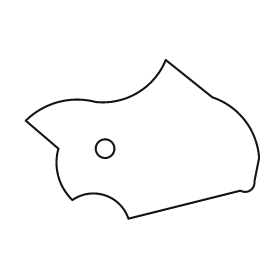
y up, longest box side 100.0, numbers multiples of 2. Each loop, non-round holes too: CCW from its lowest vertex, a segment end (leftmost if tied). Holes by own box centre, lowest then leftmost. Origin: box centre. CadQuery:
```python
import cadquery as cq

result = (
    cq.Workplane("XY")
    .moveTo(-6.0, -34.0)
    .lineTo(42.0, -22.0)
    .threePointArc((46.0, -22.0), (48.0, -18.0))
    .lineTo(50.0, -8.0)
    .threePointArc((44.0, 8.0), (30.0, 18.0))
    .lineTo(10.0, 34.0)
    .threePointArc((-2.0, 20.0), (-20.0, 16.0))
    .threePointArc((-36.0, 16.0), (-50.0, 8.0))
    .lineTo(-36.0, -4.0)
    .threePointArc((-36.0, -16.0), (-30.0, -26.0))
    .threePointArc((-16.0, -24.0), (-6.0, -34.0))
    .close()
    .moveTo(-16.0, -4.0)
    .circle(4.0)
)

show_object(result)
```